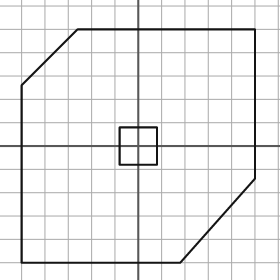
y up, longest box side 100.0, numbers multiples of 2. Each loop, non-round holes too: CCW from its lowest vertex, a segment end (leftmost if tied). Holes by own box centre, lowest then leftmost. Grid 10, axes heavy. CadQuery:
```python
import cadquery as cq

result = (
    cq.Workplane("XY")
    .moveTo(-50.0, -50.0)
    .lineTo(18.0, -50.0)
    .lineTo(50.0, -14.0)
    .lineTo(50.0, 50.0)
    .lineTo(-26.0, 50.0)
    .lineTo(-50.0, 26.0)
    .close()
    .moveTo(-8.0, -8.0)
    .lineTo(8.0, -8.0)
    .lineTo(8.0, 8.0)
    .lineTo(-8.0, 8.0)
    .close()
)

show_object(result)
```